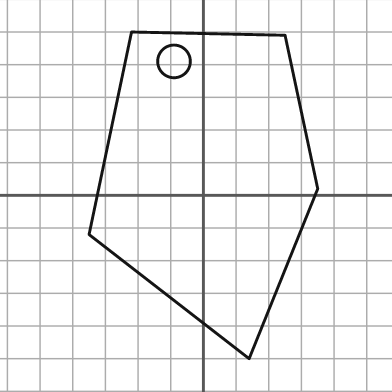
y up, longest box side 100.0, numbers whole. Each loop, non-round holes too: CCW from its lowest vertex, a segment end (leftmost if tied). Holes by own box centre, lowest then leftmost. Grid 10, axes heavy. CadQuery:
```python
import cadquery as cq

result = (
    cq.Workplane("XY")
    .moveTo(14.0, -50.0)
    .lineTo(35.0, 2.0)
    .lineTo(25.0, 49.0)
    .lineTo(-22.0, 50.0)
    .lineTo(-35.0, -12.0)
    .close()
    .moveTo(-9.0, 41.0)
    .circle(5.0)
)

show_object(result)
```